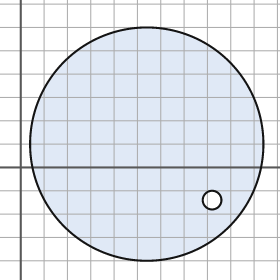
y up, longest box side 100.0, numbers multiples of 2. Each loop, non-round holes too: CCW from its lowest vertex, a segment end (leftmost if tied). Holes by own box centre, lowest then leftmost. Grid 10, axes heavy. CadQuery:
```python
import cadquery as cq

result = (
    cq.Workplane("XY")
    .moveTo(54.0, 10.0)
    .circle(50.0)
    .moveTo(82.0, -14.0)
    .circle(4.0)
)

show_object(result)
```